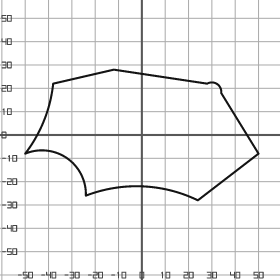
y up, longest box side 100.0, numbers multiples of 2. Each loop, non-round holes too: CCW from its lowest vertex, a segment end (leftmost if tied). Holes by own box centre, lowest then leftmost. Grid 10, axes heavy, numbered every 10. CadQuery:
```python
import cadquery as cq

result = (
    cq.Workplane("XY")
    .moveTo(24.0, -28.0)
    .lineTo(50.0, -8.0)
    .lineTo(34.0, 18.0)
    .threePointArc((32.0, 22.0), (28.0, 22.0))
    .lineTo(-12.0, 28.0)
    .lineTo(-38.0, 22.0)
    .threePointArc((-42.0, 6.0), (-50.0, -8.0))
    .threePointArc((-32.0, -10.0), (-24.0, -26.0))
    .threePointArc((0.0, -22.0), (24.0, -28.0))
    .close()
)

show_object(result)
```